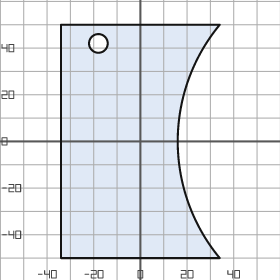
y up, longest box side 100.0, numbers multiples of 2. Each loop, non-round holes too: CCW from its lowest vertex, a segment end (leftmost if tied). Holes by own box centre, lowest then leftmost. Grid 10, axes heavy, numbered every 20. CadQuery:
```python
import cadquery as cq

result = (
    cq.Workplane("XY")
    .moveTo(-34.0, -50.0)
    .lineTo(34.0, -50.0)
    .threePointArc((16.0, 0.0), (34.0, 50.0))
    .lineTo(-34.0, 50.0)
    .close()
    .moveTo(-18.0, 42.0)
    .circle(4.0)
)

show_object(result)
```